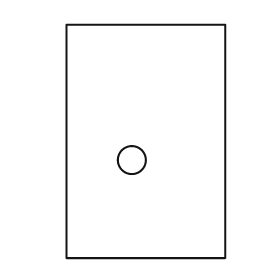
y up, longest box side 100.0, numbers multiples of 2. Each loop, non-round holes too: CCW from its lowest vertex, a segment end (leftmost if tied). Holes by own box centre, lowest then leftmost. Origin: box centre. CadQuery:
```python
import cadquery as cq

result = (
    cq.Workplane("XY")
    .moveTo(-34.0, -50.0)
    .lineTo(34.0, -50.0)
    .lineTo(34.0, 50.0)
    .lineTo(-34.0, 50.0)
    .close()
    .moveTo(-6.0, -8.0)
    .circle(6.0)
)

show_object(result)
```